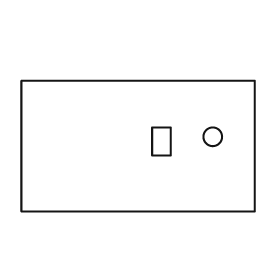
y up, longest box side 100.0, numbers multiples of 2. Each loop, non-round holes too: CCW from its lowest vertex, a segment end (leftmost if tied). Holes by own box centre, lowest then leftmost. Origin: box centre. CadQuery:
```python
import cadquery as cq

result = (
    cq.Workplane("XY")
    .moveTo(-50.0, -28.0)
    .lineTo(50.0, -28.0)
    .lineTo(50.0, 28.0)
    .lineTo(-50.0, 28.0)
    .close()
    .moveTo(6.0, -4.0)
    .lineTo(14.0, -4.0)
    .lineTo(14.0, 8.0)
    .lineTo(6.0, 8.0)
    .close()
    .moveTo(32.0, 4.0)
    .circle(4.0)
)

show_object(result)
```